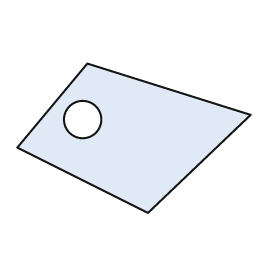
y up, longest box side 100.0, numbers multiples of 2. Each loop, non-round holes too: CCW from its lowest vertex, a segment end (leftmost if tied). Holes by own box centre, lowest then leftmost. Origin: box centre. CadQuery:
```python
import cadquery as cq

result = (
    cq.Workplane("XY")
    .moveTo(6.0, -32.0)
    .lineTo(50.0, 10.0)
    .lineTo(-20.0, 32.0)
    .lineTo(-50.0, -4.0)
    .close()
    .moveTo(-22.0, 8.0)
    .circle(8.0)
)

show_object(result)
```